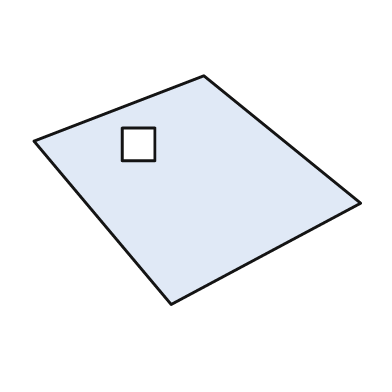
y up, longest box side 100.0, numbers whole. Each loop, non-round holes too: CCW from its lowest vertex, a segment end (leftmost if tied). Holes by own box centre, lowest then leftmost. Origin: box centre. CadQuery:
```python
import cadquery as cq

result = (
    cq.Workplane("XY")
    .moveTo(-8.0, -35.0)
    .lineTo(50.0, -4.0)
    .lineTo(2.0, 35.0)
    .lineTo(-50.0, 15.0)
    .close()
    .moveTo(-23.0, 9.0)
    .lineTo(-13.0, 9.0)
    .lineTo(-13.0, 19.0)
    .lineTo(-23.0, 19.0)
    .close()
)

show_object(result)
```